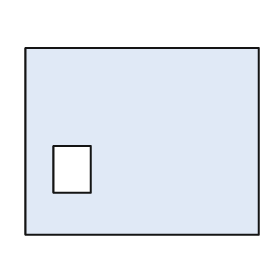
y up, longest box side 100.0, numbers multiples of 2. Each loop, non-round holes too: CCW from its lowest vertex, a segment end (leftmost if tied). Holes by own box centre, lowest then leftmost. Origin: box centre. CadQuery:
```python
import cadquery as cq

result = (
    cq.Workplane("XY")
    .moveTo(-50.0, -40.0)
    .lineTo(50.0, -40.0)
    .lineTo(50.0, 40.0)
    .lineTo(-50.0, 40.0)
    .close()
    .moveTo(-38.0, -22.0)
    .lineTo(-22.0, -22.0)
    .lineTo(-22.0, -2.0)
    .lineTo(-38.0, -2.0)
    .close()
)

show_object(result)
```